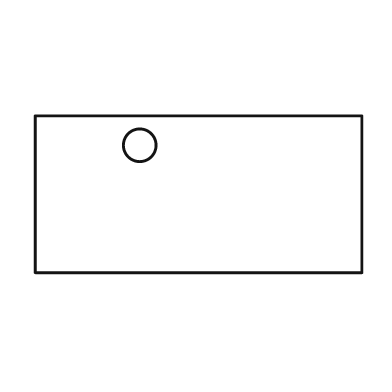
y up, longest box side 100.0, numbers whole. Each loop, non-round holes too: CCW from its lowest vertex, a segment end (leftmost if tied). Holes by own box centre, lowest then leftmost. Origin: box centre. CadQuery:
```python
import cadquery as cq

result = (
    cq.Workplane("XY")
    .moveTo(-50.0, -24.0)
    .lineTo(50.0, -24.0)
    .lineTo(50.0, 24.0)
    .lineTo(-50.0, 24.0)
    .close()
    .moveTo(-18.0, 15.0)
    .circle(5.0)
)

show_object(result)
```